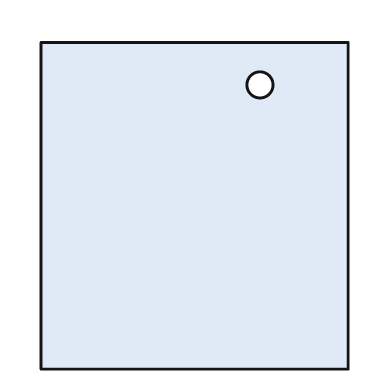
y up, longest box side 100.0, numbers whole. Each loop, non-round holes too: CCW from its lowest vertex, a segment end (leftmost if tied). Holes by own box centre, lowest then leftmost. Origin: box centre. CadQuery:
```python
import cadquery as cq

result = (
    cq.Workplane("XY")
    .moveTo(-47.0, -50.0)
    .lineTo(47.0, -50.0)
    .lineTo(47.0, 50.0)
    .lineTo(-47.0, 50.0)
    .close()
    .moveTo(20.0, 37.0)
    .circle(4.0)
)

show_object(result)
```